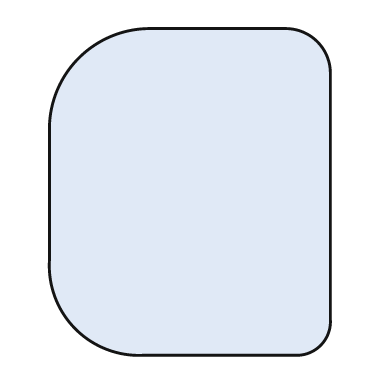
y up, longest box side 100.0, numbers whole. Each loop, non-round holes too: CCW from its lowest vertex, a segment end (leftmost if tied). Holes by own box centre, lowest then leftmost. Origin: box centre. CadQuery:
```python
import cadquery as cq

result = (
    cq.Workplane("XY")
    .moveTo(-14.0, -50.0)
    .lineTo(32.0, -50.0)
    .threePointArc((40.0, -47.0), (43.0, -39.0))
    .lineTo(43.0, 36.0)
    .threePointArc((39.0, 46.0), (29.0, 50.0))
    .lineTo(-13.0, 50.0)
    .threePointArc((-34.0, 41.0), (-43.0, 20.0))
    .lineTo(-43.0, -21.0)
    .threePointArc((-35.0, -42.0), (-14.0, -50.0))
    .close()
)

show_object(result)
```